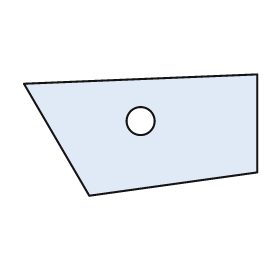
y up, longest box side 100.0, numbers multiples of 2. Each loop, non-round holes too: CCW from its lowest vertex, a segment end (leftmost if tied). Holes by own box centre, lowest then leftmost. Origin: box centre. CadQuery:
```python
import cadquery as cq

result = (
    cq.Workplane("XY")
    .moveTo(-22.0, -26.0)
    .lineTo(50.0, -16.0)
    .lineTo(50.0, 26.0)
    .lineTo(-50.0, 22.0)
    .close()
    .moveTo(0.0, 6.0)
    .circle(6.0)
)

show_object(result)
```